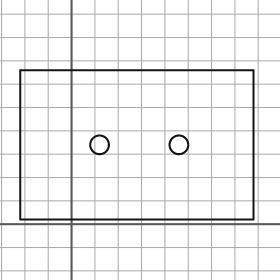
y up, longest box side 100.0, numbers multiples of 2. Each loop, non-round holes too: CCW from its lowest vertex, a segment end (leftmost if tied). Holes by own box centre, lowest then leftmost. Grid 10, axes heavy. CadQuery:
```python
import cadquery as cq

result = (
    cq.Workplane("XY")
    .moveTo(-22.0, 2.0)
    .lineTo(78.0, 2.0)
    .lineTo(78.0, 66.0)
    .lineTo(-22.0, 66.0)
    .close()
    .moveTo(12.0, 34.0)
    .circle(4.0)
    .moveTo(46.0, 34.0)
    .circle(4.0)
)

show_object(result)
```